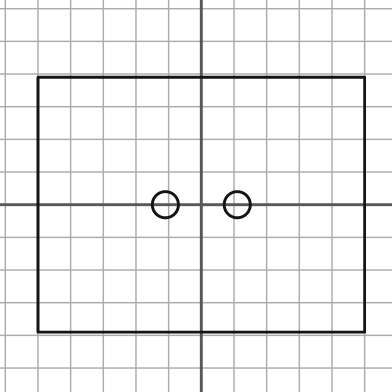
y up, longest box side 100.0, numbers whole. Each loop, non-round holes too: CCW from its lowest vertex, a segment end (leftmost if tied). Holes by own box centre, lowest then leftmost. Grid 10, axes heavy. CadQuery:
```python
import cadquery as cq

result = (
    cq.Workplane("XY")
    .moveTo(-50.0, -39.0)
    .lineTo(50.0, -39.0)
    .lineTo(50.0, 39.0)
    .lineTo(-50.0, 39.0)
    .close()
    .moveTo(-11.0, 0.0)
    .circle(4.0)
    .moveTo(11.0, 0.0)
    .circle(4.0)
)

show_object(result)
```